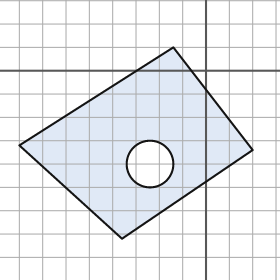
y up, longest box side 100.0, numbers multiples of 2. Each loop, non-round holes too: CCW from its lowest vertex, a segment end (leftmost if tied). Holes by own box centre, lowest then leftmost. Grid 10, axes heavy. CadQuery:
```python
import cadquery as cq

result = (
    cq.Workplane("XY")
    .moveTo(-36.0, -72.0)
    .lineTo(20.0, -34.0)
    .lineTo(-14.0, 10.0)
    .lineTo(-80.0, -32.0)
    .close()
    .moveTo(-24.0, -40.0)
    .circle(10.0)
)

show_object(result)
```